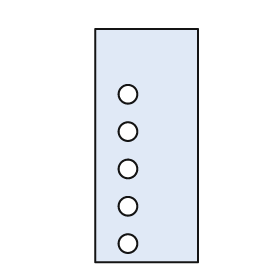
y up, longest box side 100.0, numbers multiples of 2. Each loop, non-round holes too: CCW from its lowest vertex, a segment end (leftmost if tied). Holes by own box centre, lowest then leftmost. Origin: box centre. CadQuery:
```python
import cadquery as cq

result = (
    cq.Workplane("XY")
    .moveTo(-22.0, -50.0)
    .lineTo(22.0, -50.0)
    .lineTo(22.0, 50.0)
    .lineTo(-22.0, 50.0)
    .close()
    .moveTo(-8.0, -42.0)
    .circle(4.0)
    .moveTo(-8.0, -26.0)
    .circle(4.0)
    .moveTo(-8.0, -10.0)
    .circle(4.0)
    .moveTo(-8.0, 6.0)
    .circle(4.0)
    .moveTo(-8.0, 22.0)
    .circle(4.0)
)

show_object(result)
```